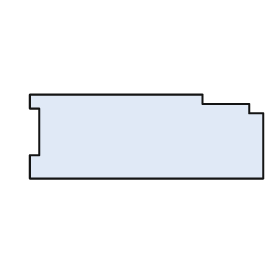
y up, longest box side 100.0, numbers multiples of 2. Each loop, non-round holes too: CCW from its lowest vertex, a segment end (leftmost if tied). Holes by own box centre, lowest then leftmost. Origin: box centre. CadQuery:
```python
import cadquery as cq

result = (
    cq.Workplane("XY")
    .moveTo(-50.0, -18.0)
    .lineTo(50.0, -18.0)
    .lineTo(50.0, 10.0)
    .lineTo(44.0, 10.0)
    .lineTo(44.0, 14.0)
    .lineTo(24.0, 14.0)
    .lineTo(24.0, 18.0)
    .lineTo(-50.0, 18.0)
    .lineTo(-50.0, 12.0)
    .lineTo(-46.0, 12.0)
    .lineTo(-46.0, -8.0)
    .lineTo(-50.0, -8.0)
    .close()
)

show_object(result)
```